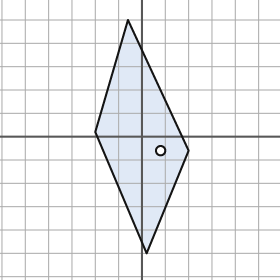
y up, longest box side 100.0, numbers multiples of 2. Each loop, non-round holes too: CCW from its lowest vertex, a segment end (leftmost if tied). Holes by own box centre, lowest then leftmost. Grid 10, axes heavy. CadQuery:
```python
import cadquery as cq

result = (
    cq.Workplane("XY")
    .moveTo(2.0, -50.0)
    .lineTo(20.0, -6.0)
    .lineTo(-6.0, 50.0)
    .lineTo(-20.0, 2.0)
    .close()
    .moveTo(8.0, -6.0)
    .circle(2.0)
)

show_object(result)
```